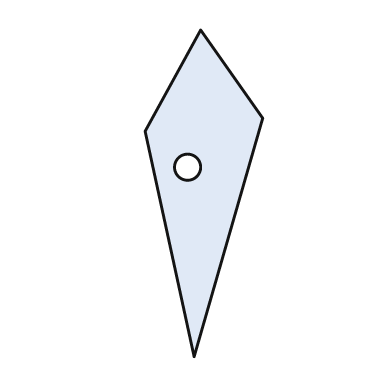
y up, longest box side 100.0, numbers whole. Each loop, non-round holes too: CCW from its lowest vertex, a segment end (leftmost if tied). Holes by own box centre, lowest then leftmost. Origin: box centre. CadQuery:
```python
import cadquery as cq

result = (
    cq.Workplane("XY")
    .moveTo(-3.0, -50.0)
    .lineTo(18.0, 23.0)
    .lineTo(-1.0, 50.0)
    .lineTo(-18.0, 19.0)
    .close()
    .moveTo(-5.0, 8.0)
    .circle(4.0)
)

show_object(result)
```